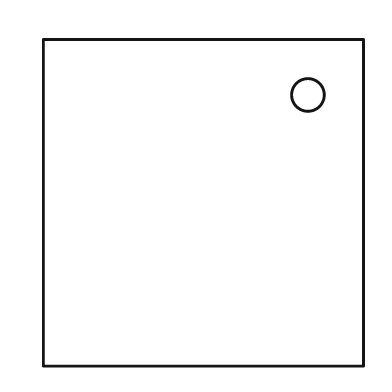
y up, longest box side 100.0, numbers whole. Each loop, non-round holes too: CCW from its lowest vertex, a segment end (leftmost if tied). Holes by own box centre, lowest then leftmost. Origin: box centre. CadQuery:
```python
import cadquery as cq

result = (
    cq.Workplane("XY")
    .moveTo(-49.0, -50.0)
    .lineTo(49.0, -50.0)
    .lineTo(49.0, 50.0)
    .lineTo(-49.0, 50.0)
    .close()
    .moveTo(32.0, 33.0)
    .circle(5.0)
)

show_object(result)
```